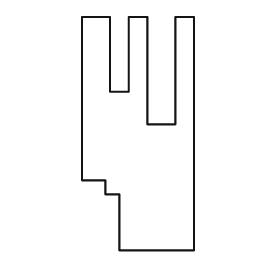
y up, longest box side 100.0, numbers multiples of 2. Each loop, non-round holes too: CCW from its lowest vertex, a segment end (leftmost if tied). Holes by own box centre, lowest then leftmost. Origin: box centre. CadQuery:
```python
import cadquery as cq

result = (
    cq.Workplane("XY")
    .moveTo(-8.0, -50.0)
    .lineTo(24.0, -50.0)
    .lineTo(24.0, 50.0)
    .lineTo(16.0, 50.0)
    .lineTo(16.0, 4.0)
    .lineTo(4.0, 4.0)
    .lineTo(4.0, 50.0)
    .lineTo(-4.0, 50.0)
    .lineTo(-4.0, 18.0)
    .lineTo(-12.0, 18.0)
    .lineTo(-12.0, 50.0)
    .lineTo(-24.0, 50.0)
    .lineTo(-24.0, -20.0)
    .lineTo(-14.0, -20.0)
    .lineTo(-14.0, -26.0)
    .lineTo(-8.0, -26.0)
    .close()
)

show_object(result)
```